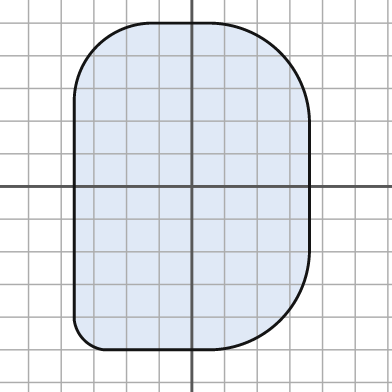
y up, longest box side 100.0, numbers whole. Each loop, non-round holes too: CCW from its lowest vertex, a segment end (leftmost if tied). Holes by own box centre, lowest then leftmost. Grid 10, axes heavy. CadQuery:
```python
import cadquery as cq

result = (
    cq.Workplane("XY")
    .moveTo(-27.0, -50.0)
    .lineTo(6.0, -50.0)
    .threePointArc((27.0, -41.0), (36.0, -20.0))
    .lineTo(36.0, 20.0)
    .threePointArc((27.0, 41.0), (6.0, 50.0))
    .lineTo(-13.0, 50.0)
    .threePointArc((-29.0, 43.0), (-36.0, 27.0))
    .lineTo(-36.0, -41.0)
    .threePointArc((-33.0, -47.0), (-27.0, -50.0))
    .close()
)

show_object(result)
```